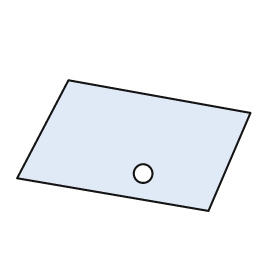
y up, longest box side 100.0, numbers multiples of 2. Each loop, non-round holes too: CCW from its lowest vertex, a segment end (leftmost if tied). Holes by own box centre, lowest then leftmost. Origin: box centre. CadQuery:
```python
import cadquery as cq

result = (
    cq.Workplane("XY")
    .moveTo(32.0, -28.0)
    .lineTo(50.0, 14.0)
    .lineTo(-28.0, 28.0)
    .lineTo(-50.0, -14.0)
    .close()
    .moveTo(4.0, -12.0)
    .circle(4.0)
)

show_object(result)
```